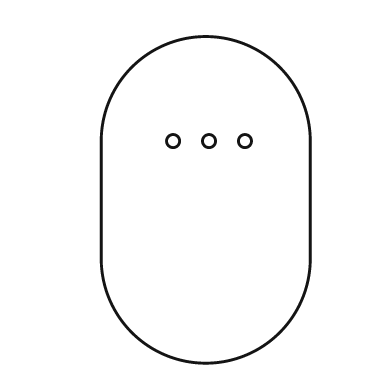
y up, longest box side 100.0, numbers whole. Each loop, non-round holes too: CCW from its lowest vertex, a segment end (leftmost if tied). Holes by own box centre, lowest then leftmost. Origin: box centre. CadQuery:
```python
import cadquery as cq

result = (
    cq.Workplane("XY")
    .moveTo(-32.0, -18.0)
    .threePointArc((0.0, -50.0), (32.0, -18.0))
    .lineTo(32.0, 18.0)
    .threePointArc((0.0, 50.0), (-32.0, 18.0))
    .close()
    .moveTo(-10.0, 18.0)
    .circle(2.0)
    .moveTo(1.0, 18.0)
    .circle(2.0)
    .moveTo(12.0, 18.0)
    .circle(2.0)
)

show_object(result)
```